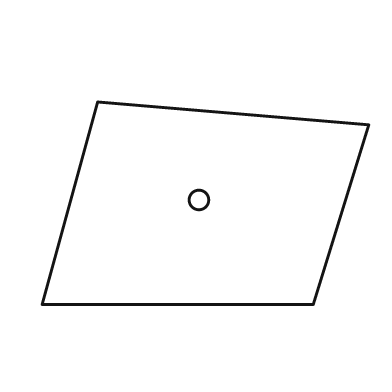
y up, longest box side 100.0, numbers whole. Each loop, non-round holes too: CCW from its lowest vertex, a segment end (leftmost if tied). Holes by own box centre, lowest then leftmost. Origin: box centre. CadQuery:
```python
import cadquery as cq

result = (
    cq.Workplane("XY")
    .moveTo(-50.0, -31.0)
    .lineTo(33.0, -31.0)
    .lineTo(50.0, 24.0)
    .lineTo(-33.0, 31.0)
    .close()
    .moveTo(-2.0, 1.0)
    .circle(3.0)
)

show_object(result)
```